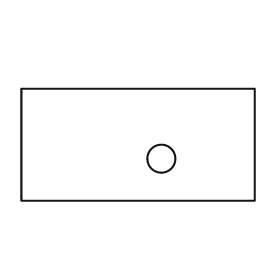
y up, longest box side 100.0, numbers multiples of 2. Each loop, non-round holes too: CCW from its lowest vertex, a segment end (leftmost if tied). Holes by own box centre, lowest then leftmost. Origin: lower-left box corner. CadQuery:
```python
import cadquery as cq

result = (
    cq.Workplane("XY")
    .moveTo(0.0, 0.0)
    .lineTo(100.0, 0.0)
    .lineTo(100.0, 48.0)
    .lineTo(0.0, 48.0)
    .close()
    .moveTo(60.0, 18.0)
    .circle(6.0)
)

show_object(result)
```